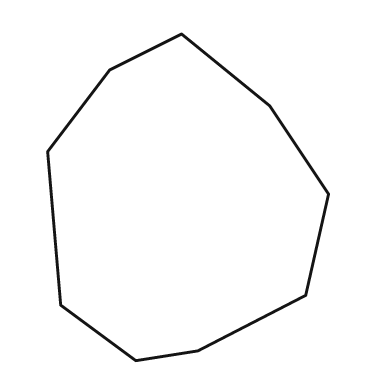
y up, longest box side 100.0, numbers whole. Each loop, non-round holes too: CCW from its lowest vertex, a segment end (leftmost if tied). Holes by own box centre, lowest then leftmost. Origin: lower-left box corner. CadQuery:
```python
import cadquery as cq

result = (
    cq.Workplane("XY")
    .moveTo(27.0, 0.0)
    .lineTo(46.0, 3.0)
    .lineTo(79.0, 20.0)
    .lineTo(86.0, 51.0)
    .lineTo(68.0, 78.0)
    .lineTo(41.0, 100.0)
    .lineTo(19.0, 89.0)
    .lineTo(0.0, 64.0)
    .lineTo(4.0, 17.0)
    .close()
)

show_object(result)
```